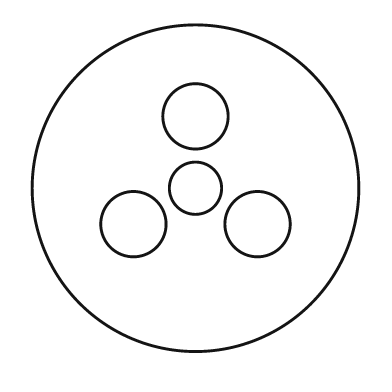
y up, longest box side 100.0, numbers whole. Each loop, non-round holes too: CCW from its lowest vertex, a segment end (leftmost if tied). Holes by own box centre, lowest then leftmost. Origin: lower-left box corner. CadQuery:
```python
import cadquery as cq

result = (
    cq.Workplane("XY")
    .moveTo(50.0, 50.0)
    .circle(50.0)
    .moveTo(31.0, 39.0)
    .circle(10.0)
    .moveTo(69.0, 39.0)
    .circle(10.0)
    .moveTo(50.0, 50.0)
    .circle(8.0)
    .moveTo(50.0, 72.0)
    .circle(10.0)
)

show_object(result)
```